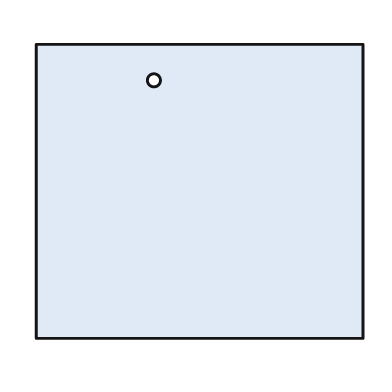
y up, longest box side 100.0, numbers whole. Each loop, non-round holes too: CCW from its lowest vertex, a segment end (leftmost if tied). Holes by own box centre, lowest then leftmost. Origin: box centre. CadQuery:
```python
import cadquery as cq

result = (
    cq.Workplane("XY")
    .moveTo(-50.0, -45.0)
    .lineTo(50.0, -45.0)
    .lineTo(50.0, 45.0)
    .lineTo(-50.0, 45.0)
    .close()
    .moveTo(-14.0, 34.0)
    .circle(2.0)
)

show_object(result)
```